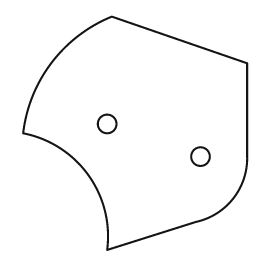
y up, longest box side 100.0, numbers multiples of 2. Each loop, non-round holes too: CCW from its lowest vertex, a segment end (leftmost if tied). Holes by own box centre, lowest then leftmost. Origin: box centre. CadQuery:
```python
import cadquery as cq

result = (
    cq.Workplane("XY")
    .moveTo(-12.0, -50.0)
    .lineTo(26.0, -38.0)
    .threePointArc((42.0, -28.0), (48.0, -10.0))
    .lineTo(48.0, 30.0)
    .lineTo(-10.0, 50.0)
    .threePointArc((-36.0, 30.0), (-48.0, 0.0))
    .threePointArc((-20.0, -18.0), (-12.0, -50.0))
    .close()
    .moveTo(28.0, -10.0)
    .circle(4.0)
    .moveTo(-12.0, 4.0)
    .circle(4.0)
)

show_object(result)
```